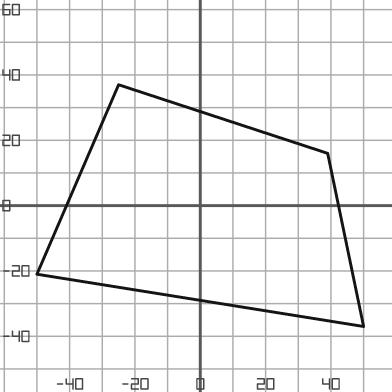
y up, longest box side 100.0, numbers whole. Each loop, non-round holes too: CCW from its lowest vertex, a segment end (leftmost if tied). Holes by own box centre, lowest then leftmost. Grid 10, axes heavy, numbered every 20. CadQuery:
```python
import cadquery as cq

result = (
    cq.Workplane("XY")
    .moveTo(50.0, -37.0)
    .lineTo(39.0, 16.0)
    .lineTo(-25.0, 37.0)
    .lineTo(-50.0, -21.0)
    .close()
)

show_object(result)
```